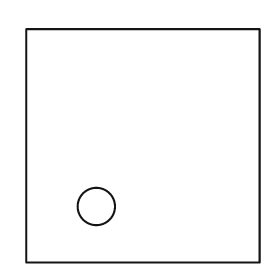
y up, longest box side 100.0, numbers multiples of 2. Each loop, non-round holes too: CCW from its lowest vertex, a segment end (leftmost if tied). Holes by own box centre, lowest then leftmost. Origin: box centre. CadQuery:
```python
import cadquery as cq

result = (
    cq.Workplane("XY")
    .moveTo(-50.0, -50.0)
    .lineTo(50.0, -50.0)
    .lineTo(50.0, 50.0)
    .lineTo(-50.0, 50.0)
    .close()
    .moveTo(-20.0, -26.0)
    .circle(8.0)
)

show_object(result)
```